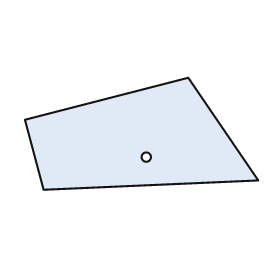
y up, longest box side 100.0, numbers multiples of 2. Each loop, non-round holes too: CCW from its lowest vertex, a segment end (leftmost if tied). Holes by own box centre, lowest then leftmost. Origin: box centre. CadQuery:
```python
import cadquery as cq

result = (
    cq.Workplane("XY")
    .moveTo(-42.0, -24.0)
    .lineTo(50.0, -20.0)
    .lineTo(20.0, 24.0)
    .lineTo(-50.0, 6.0)
    .close()
    .moveTo(2.0, -10.0)
    .circle(2.0)
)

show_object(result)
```